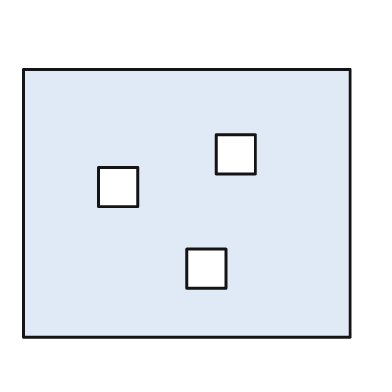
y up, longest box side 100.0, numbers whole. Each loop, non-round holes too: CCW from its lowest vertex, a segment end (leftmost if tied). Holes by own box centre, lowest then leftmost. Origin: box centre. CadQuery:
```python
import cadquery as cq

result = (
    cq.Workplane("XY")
    .moveTo(-50.0, -41.0)
    .lineTo(50.0, -41.0)
    .lineTo(50.0, 41.0)
    .lineTo(-50.0, 41.0)
    .close()
    .moveTo(0.0, -26.0)
    .lineTo(12.0, -26.0)
    .lineTo(12.0, -14.0)
    .lineTo(0.0, -14.0)
    .close()
    .moveTo(-27.0, -1.0)
    .lineTo(-15.0, -1.0)
    .lineTo(-15.0, 11.0)
    .lineTo(-27.0, 11.0)
    .close()
    .moveTo(9.0, 9.0)
    .lineTo(21.0, 9.0)
    .lineTo(21.0, 21.0)
    .lineTo(9.0, 21.0)
    .close()
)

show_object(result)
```